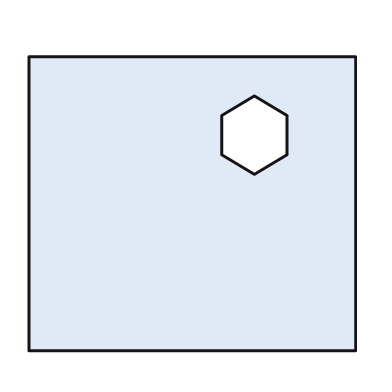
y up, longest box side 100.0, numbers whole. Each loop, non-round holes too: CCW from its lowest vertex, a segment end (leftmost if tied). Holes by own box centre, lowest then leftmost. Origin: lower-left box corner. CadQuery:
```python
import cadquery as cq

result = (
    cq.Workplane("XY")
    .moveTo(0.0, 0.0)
    .lineTo(100.0, 0.0)
    .lineTo(100.0, 90.0)
    .lineTo(0.0, 90.0)
    .close()
    .moveTo(69.0, 54.0)
    .lineTo(79.0, 60.0)
    .lineTo(79.0, 72.0)
    .lineTo(69.0, 78.0)
    .lineTo(59.0, 72.0)
    .lineTo(59.0, 60.0)
    .close()
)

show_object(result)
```